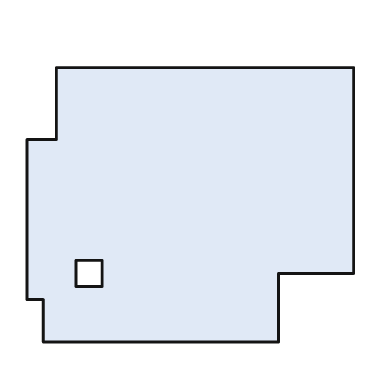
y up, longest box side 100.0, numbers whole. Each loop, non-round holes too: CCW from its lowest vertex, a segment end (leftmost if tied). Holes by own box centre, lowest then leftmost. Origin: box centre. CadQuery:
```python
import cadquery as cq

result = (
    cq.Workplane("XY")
    .moveTo(-45.0, -42.0)
    .lineTo(27.0, -42.0)
    .lineTo(27.0, -21.0)
    .lineTo(50.0, -21.0)
    .lineTo(50.0, 42.0)
    .lineTo(-41.0, 42.0)
    .lineTo(-41.0, 20.0)
    .lineTo(-50.0, 20.0)
    .lineTo(-50.0, -29.0)
    .lineTo(-45.0, -29.0)
    .close()
    .moveTo(-35.0, -25.0)
    .lineTo(-27.0, -25.0)
    .lineTo(-27.0, -17.0)
    .lineTo(-35.0, -17.0)
    .close()
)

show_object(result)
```